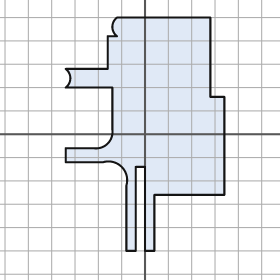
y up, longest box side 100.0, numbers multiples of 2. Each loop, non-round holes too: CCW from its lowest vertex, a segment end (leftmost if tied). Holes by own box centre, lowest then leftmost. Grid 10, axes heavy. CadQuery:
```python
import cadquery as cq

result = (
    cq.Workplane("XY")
    .moveTo(-8.0, -50.0)
    .lineTo(-4.0, -50.0)
    .lineTo(-4.0, -14.0)
    .lineTo(0.0, -14.0)
    .lineTo(0.0, -50.0)
    .lineTo(4.0, -50.0)
    .lineTo(4.0, -26.0)
    .lineTo(34.0, -26.0)
    .lineTo(34.0, 16.0)
    .lineTo(28.0, 16.0)
    .lineTo(28.0, 50.0)
    .lineTo(-12.0, 50.0)
    .threePointArc((-14.0, 46.0), (-12.0, 42.0))
    .lineTo(-16.0, 42.0)
    .lineTo(-16.0, 28.0)
    .lineTo(-34.0, 28.0)
    .threePointArc((-32.0, 24.0), (-34.0, 20.0))
    .lineTo(-14.0, 20.0)
    .lineTo(-14.0, 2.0)
    .threePointArc((-16.0, -4.0), (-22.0, -6.0))
    .lineTo(-34.0, -6.0)
    .lineTo(-34.0, -12.0)
    .lineTo(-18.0, -12.0)
    .threePointArc((-10.0, -14.0), (-8.0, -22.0))
    .close()
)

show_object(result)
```